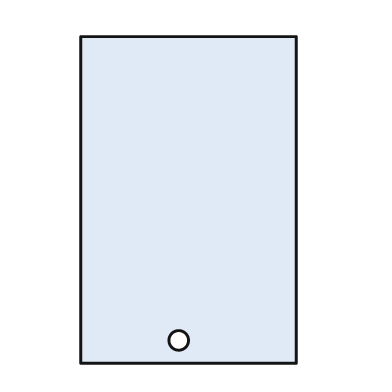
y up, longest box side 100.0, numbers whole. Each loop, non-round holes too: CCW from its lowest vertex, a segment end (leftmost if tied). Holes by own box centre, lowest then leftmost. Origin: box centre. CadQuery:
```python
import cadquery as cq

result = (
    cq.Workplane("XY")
    .moveTo(-33.0, -50.0)
    .lineTo(33.0, -50.0)
    .lineTo(33.0, 50.0)
    .lineTo(-33.0, 50.0)
    .close()
    .moveTo(-3.0, -43.0)
    .circle(3.0)
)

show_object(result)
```